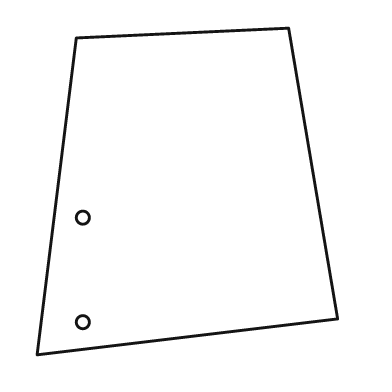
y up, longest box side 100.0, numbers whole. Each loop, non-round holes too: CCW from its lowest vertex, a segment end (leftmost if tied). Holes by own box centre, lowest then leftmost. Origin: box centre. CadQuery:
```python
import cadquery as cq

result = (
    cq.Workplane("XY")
    .moveTo(-46.0, -50.0)
    .lineTo(46.0, -39.0)
    .lineTo(31.0, 50.0)
    .lineTo(-34.0, 47.0)
    .close()
    .moveTo(-32.0, -40.0)
    .circle(2.0)
    .moveTo(-32.0, -8.0)
    .circle(2.0)
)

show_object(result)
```